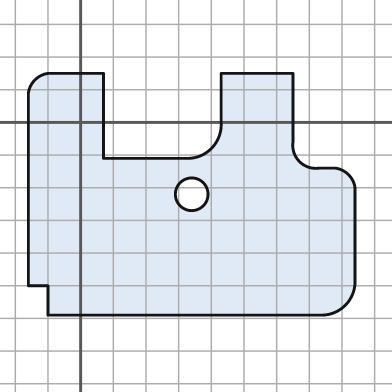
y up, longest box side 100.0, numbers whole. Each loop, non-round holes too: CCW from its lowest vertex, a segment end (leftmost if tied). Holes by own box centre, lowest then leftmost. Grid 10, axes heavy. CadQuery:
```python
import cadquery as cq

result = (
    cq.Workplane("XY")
    .moveTo(-10.0, -59.0)
    .lineTo(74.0, -59.0)
    .threePointArc((81.0, -56.0), (84.0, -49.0))
    .lineTo(84.0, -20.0)
    .threePointArc((82.0, -16.0), (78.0, -14.0))
    .lineTo(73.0, -14.0)
    .threePointArc((67.0, -12.0), (65.0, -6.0))
    .lineTo(65.0, 15.0)
    .lineTo(43.0, 15.0)
    .lineTo(43.0, 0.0)
    .threePointArc((40.0, -8.0), (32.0, -11.0))
    .lineTo(7.0, -11.0)
    .lineTo(7.0, 15.0)
    .lineTo(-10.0, 15.0)
    .threePointArc((-14.0, 13.0), (-16.0, 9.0))
    .lineTo(-16.0, -50.0)
    .lineTo(-10.0, -50.0)
    .close()
    .moveTo(34.0, -22.0)
    .circle(5.0)
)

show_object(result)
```